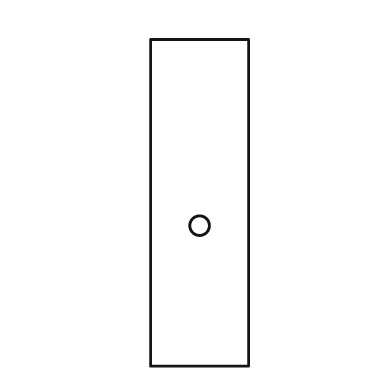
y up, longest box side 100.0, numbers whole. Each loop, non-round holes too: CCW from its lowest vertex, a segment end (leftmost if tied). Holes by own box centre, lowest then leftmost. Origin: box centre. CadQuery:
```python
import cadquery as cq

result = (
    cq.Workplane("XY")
    .moveTo(-15.0, -50.0)
    .lineTo(15.0, -50.0)
    .lineTo(15.0, 50.0)
    .lineTo(-15.0, 50.0)
    .close()
    .moveTo(0.0, -7.0)
    .circle(3.0)
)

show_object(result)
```